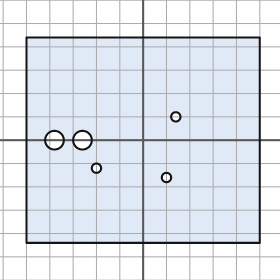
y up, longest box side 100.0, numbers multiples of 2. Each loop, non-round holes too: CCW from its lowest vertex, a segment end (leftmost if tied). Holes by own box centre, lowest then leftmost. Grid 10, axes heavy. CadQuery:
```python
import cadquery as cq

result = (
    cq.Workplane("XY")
    .moveTo(-50.0, -44.0)
    .lineTo(50.0, -44.0)
    .lineTo(50.0, 44.0)
    .lineTo(-50.0, 44.0)
    .close()
    .moveTo(10.0, -16.0)
    .circle(2.0)
    .moveTo(-20.0, -12.0)
    .circle(2.0)
    .moveTo(-38.0, 0.0)
    .circle(4.0)
    .moveTo(-26.0, 0.0)
    .circle(4.0)
    .moveTo(14.0, 10.0)
    .circle(2.0)
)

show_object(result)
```